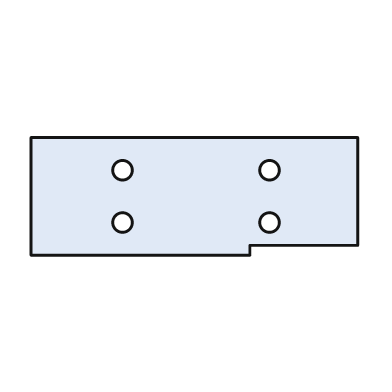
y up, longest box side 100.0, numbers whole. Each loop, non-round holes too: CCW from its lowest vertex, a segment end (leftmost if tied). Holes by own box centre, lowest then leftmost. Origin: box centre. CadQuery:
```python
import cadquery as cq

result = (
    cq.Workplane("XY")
    .moveTo(-50.0, -18.0)
    .lineTo(17.0, -18.0)
    .lineTo(17.0, -15.0)
    .lineTo(50.0, -15.0)
    .lineTo(50.0, 18.0)
    .lineTo(-50.0, 18.0)
    .close()
    .moveTo(-22.0, -8.0)
    .circle(3.0)
    .moveTo(23.0, -8.0)
    .circle(3.0)
    .moveTo(-22.0, 8.0)
    .circle(3.0)
    .moveTo(23.0, 8.0)
    .circle(3.0)
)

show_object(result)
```